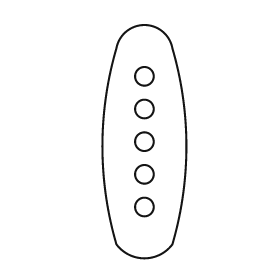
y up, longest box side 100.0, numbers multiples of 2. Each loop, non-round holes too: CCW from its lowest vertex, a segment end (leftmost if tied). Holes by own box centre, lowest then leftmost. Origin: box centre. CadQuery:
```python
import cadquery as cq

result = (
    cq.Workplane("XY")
    .moveTo(-12.0, -44.0)
    .threePointArc((0.0, -50.0), (12.0, -44.0))
    .threePointArc((18.0, -2.0), (12.0, 40.0))
    .threePointArc((0.0, 50.0), (-12.0, 40.0))
    .threePointArc((-18.0, -2.0), (-12.0, -44.0))
    .close()
    .moveTo(0.0, -28.0)
    .circle(4.0)
    .moveTo(0.0, -14.0)
    .circle(4.0)
    .moveTo(0.0, 0.0)
    .circle(4.0)
    .moveTo(0.0, 14.0)
    .circle(4.0)
    .moveTo(0.0, 28.0)
    .circle(4.0)
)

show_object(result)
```